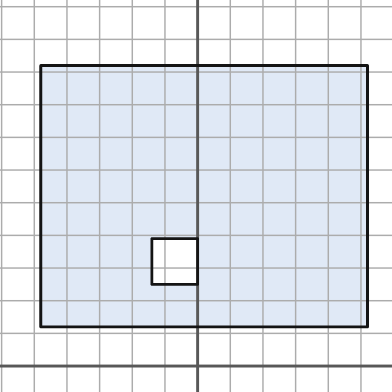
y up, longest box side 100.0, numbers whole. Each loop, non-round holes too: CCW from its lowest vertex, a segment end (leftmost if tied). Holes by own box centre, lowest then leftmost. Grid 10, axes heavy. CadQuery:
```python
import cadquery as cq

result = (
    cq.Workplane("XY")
    .moveTo(-48.0, 12.0)
    .lineTo(52.0, 12.0)
    .lineTo(52.0, 92.0)
    .lineTo(-48.0, 92.0)
    .close()
    .moveTo(-14.0, 25.0)
    .lineTo(0.0, 25.0)
    .lineTo(0.0, 39.0)
    .lineTo(-14.0, 39.0)
    .close()
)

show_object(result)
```